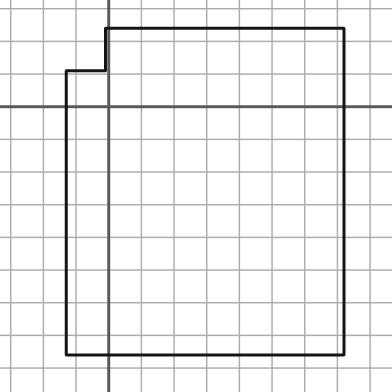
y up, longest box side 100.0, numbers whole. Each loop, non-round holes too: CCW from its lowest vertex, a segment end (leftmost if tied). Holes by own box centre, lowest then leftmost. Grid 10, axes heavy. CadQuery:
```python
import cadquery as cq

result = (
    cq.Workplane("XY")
    .moveTo(-13.0, -76.0)
    .lineTo(72.0, -76.0)
    .lineTo(72.0, 24.0)
    .lineTo(-1.0, 24.0)
    .lineTo(-1.0, 11.0)
    .lineTo(-13.0, 11.0)
    .close()
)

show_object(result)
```